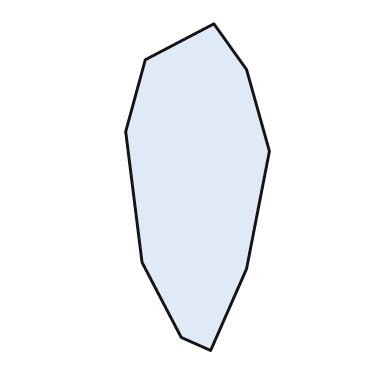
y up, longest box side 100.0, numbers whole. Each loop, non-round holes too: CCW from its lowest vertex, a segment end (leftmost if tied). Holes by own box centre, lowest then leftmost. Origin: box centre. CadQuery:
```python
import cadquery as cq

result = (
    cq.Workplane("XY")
    .moveTo(4.0, -50.0)
    .lineTo(15.0, -25.0)
    .lineTo(22.0, 11.0)
    .lineTo(15.0, 36.0)
    .lineTo(5.0, 50.0)
    .lineTo(-16.0, 39.0)
    .lineTo(-22.0, 17.0)
    .lineTo(-17.0, -23.0)
    .lineTo(-5.0, -46.0)
    .close()
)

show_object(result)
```